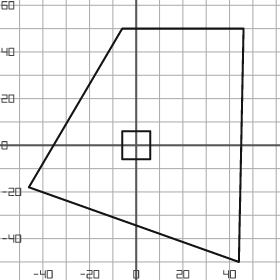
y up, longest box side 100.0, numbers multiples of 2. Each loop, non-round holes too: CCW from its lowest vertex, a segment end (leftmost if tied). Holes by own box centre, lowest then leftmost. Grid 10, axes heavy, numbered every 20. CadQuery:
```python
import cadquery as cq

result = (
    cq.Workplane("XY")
    .moveTo(44.0, -50.0)
    .lineTo(46.0, 50.0)
    .lineTo(-6.0, 50.0)
    .lineTo(-46.0, -18.0)
    .close()
    .moveTo(-6.0, -6.0)
    .lineTo(6.0, -6.0)
    .lineTo(6.0, 6.0)
    .lineTo(-6.0, 6.0)
    .close()
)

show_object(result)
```